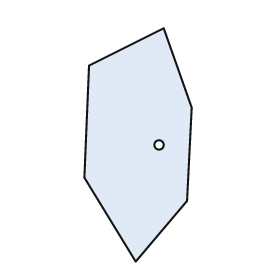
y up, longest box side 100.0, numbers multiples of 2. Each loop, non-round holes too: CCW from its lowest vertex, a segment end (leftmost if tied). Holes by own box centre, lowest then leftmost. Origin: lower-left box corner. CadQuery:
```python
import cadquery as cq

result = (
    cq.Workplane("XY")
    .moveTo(22.0, 0.0)
    .lineTo(44.0, 26.0)
    .lineTo(46.0, 66.0)
    .lineTo(34.0, 100.0)
    .lineTo(2.0, 84.0)
    .lineTo(0.0, 36.0)
    .close()
    .moveTo(32.0, 50.0)
    .circle(2.0)
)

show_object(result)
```